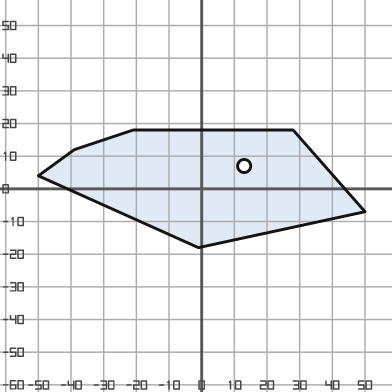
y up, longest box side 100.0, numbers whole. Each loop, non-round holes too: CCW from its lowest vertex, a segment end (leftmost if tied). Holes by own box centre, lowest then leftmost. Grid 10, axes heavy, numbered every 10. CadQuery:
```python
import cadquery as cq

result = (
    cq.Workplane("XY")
    .moveTo(-1.0, -18.0)
    .lineTo(50.0, -7.0)
    .lineTo(28.0, 18.0)
    .lineTo(-21.0, 18.0)
    .lineTo(-39.0, 12.0)
    .lineTo(-50.0, 4.0)
    .close()
    .moveTo(13.0, 7.0)
    .circle(2.0)
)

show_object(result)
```